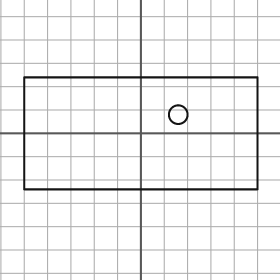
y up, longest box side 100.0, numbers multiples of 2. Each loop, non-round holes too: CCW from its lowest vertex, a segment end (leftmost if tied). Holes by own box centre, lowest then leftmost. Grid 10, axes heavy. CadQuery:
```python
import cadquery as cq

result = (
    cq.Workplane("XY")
    .moveTo(-50.0, -24.0)
    .lineTo(50.0, -24.0)
    .lineTo(50.0, 24.0)
    .lineTo(-50.0, 24.0)
    .close()
    .moveTo(16.0, 8.0)
    .circle(4.0)
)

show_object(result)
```